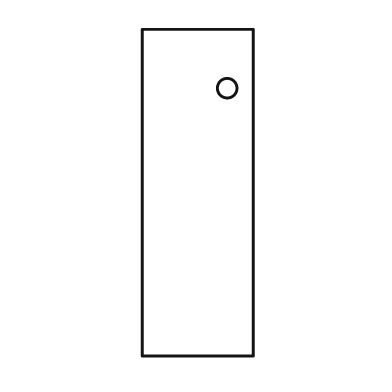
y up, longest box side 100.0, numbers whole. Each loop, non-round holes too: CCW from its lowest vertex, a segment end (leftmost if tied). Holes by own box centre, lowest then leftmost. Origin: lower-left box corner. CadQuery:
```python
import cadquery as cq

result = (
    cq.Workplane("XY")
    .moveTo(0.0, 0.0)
    .lineTo(34.0, 0.0)
    .lineTo(34.0, 100.0)
    .lineTo(0.0, 100.0)
    .close()
    .moveTo(26.0, 82.0)
    .circle(3.0)
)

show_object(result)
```